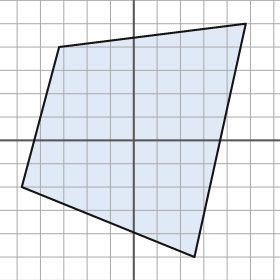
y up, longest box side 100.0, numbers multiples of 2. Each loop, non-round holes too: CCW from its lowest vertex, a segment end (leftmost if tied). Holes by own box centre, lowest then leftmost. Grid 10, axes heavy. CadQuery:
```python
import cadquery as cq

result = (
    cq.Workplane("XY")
    .moveTo(26.0, -50.0)
    .lineTo(48.0, 50.0)
    .lineTo(-32.0, 40.0)
    .lineTo(-48.0, -20.0)
    .close()
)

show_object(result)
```